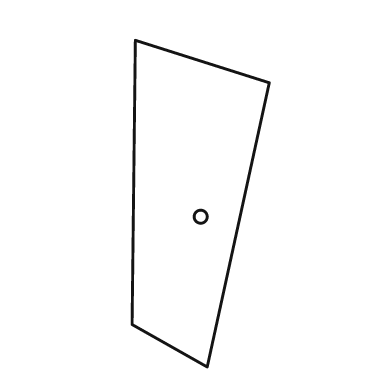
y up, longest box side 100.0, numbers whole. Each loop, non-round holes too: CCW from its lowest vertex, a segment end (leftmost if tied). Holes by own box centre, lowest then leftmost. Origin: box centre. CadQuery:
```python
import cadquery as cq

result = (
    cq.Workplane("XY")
    .moveTo(2.0, -50.0)
    .lineTo(21.0, 37.0)
    .lineTo(-20.0, 50.0)
    .lineTo(-21.0, -37.0)
    .close()
    .moveTo(0.0, -4.0)
    .circle(2.0)
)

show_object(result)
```